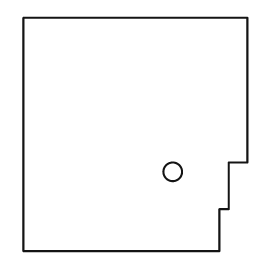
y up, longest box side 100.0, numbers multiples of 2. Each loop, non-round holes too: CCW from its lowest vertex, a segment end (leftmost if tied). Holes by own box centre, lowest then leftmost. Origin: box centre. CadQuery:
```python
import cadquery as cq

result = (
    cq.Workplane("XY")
    .moveTo(-48.0, -50.0)
    .lineTo(36.0, -50.0)
    .lineTo(36.0, -32.0)
    .lineTo(40.0, -32.0)
    .lineTo(40.0, -12.0)
    .lineTo(48.0, -12.0)
    .lineTo(48.0, 50.0)
    .lineTo(-48.0, 50.0)
    .close()
    .moveTo(16.0, -16.0)
    .circle(4.0)
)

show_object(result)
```